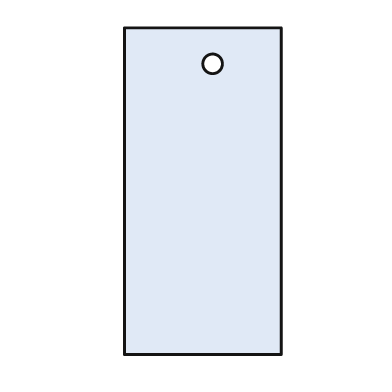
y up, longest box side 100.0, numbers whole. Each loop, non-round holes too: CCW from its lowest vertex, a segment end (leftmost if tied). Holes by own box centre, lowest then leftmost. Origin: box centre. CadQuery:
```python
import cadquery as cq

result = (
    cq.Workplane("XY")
    .moveTo(-24.0, -50.0)
    .lineTo(24.0, -50.0)
    .lineTo(24.0, 50.0)
    .lineTo(-24.0, 50.0)
    .close()
    .moveTo(3.0, 39.0)
    .circle(3.0)
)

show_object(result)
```